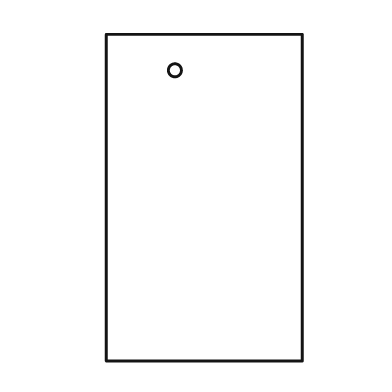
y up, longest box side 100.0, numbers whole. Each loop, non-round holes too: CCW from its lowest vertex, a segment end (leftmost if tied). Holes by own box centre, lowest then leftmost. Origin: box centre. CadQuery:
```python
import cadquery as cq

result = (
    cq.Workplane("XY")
    .moveTo(-30.0, -50.0)
    .lineTo(30.0, -50.0)
    .lineTo(30.0, 50.0)
    .lineTo(-30.0, 50.0)
    .close()
    .moveTo(-9.0, 39.0)
    .circle(2.0)
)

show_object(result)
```